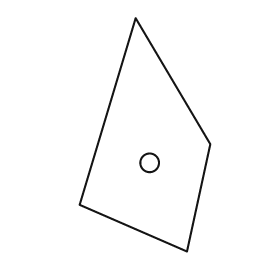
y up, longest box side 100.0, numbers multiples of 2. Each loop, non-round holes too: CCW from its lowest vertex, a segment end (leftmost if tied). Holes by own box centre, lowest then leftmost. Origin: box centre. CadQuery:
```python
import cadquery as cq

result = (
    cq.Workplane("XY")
    .moveTo(18.0, -50.0)
    .lineTo(28.0, -4.0)
    .lineTo(-4.0, 50.0)
    .lineTo(-28.0, -30.0)
    .close()
    .moveTo(2.0, -12.0)
    .circle(4.0)
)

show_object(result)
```